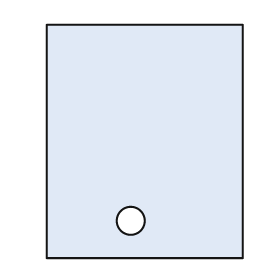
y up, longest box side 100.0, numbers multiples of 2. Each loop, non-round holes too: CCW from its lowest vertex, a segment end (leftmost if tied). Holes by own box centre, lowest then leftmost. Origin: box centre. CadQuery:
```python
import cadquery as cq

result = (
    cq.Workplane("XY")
    .moveTo(-42.0, -50.0)
    .lineTo(42.0, -50.0)
    .lineTo(42.0, 50.0)
    .lineTo(-42.0, 50.0)
    .close()
    .moveTo(-6.0, -34.0)
    .circle(6.0)
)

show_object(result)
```